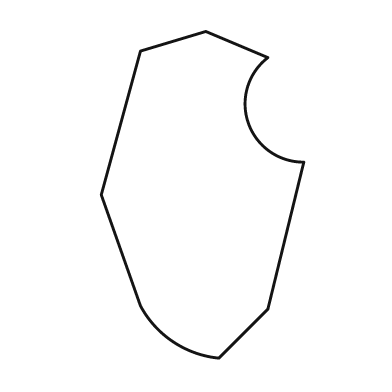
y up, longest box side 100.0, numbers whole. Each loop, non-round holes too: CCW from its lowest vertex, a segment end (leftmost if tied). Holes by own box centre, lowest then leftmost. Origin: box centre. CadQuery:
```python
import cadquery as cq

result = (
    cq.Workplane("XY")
    .moveTo(5.0, -50.0)
    .lineTo(20.0, -35.0)
    .lineTo(31.0, 10.0)
    .threePointArc((14.0, 22.0), (20.0, 42.0))
    .lineTo(1.0, 50.0)
    .lineTo(-19.0, 44.0)
    .lineTo(-31.0, 0.0)
    .lineTo(-19.0, -34.0)
    .threePointArc((-9.0, -45.0), (5.0, -50.0))
    .close()
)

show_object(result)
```